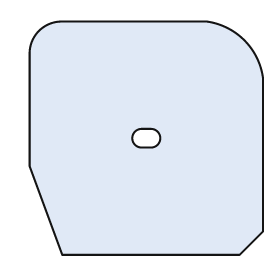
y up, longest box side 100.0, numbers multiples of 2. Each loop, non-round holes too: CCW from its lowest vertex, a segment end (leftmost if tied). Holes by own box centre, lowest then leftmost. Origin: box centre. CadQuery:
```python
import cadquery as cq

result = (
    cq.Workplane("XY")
    .moveTo(-36.0, -50.0)
    .lineTo(40.0, -50.0)
    .lineTo(50.0, -40.0)
    .lineTo(50.0, 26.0)
    .threePointArc((42.0, 42.0), (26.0, 50.0))
    .lineTo(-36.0, 50.0)
    .threePointArc((-46.0, 46.0), (-50.0, 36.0))
    .lineTo(-50.0, -12.0)
    .close()
    .moveTo(-2.0, -4.0)
    .lineTo(2.0, -4.0)
    .threePointArc((6.0, 0.0), (2.0, 4.0))
    .lineTo(-2.0, 4.0)
    .threePointArc((-6.0, 0.0), (-2.0, -4.0))
    .close()
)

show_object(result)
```